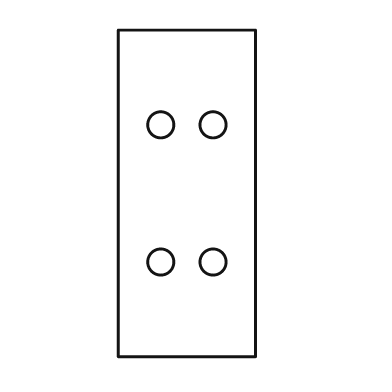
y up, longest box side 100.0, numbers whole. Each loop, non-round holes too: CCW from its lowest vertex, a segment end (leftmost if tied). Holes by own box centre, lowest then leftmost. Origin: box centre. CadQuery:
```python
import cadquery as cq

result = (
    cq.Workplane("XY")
    .moveTo(-21.0, -50.0)
    .lineTo(21.0, -50.0)
    .lineTo(21.0, 50.0)
    .lineTo(-21.0, 50.0)
    .close()
    .moveTo(-8.0, -21.0)
    .circle(4.0)
    .moveTo(8.0, -21.0)
    .circle(4.0)
    .moveTo(-8.0, 21.0)
    .circle(4.0)
    .moveTo(8.0, 21.0)
    .circle(4.0)
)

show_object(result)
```